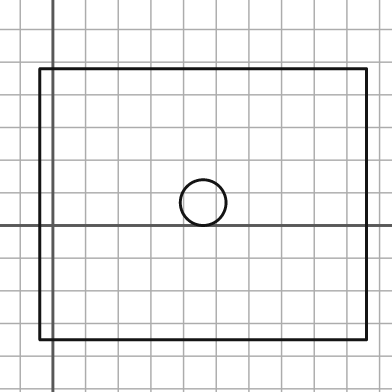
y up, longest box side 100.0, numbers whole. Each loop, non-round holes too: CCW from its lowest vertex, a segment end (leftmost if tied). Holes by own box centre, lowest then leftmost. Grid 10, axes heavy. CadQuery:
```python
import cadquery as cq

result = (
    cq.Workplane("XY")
    .moveTo(-4.0, -35.0)
    .lineTo(96.0, -35.0)
    .lineTo(96.0, 48.0)
    .lineTo(-4.0, 48.0)
    .close()
    .moveTo(46.0, 7.0)
    .circle(7.0)
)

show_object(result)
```